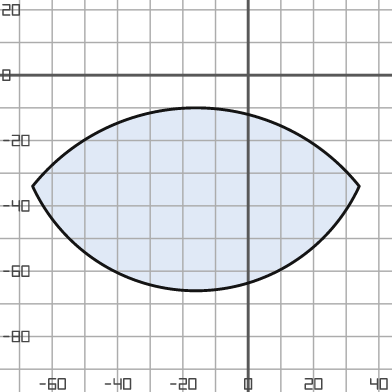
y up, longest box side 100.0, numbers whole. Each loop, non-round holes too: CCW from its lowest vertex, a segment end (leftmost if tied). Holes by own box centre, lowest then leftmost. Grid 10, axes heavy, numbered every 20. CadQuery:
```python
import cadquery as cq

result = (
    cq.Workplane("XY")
    .moveTo(-66.0, -34.0)
    .threePointArc((-16.0, -66.0), (34.0, -34.0))
    .threePointArc((-16.0, -10.0), (-66.0, -34.0))
    .close()
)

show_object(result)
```